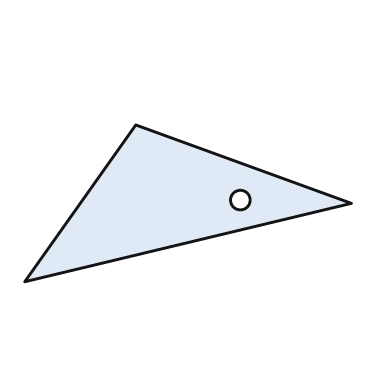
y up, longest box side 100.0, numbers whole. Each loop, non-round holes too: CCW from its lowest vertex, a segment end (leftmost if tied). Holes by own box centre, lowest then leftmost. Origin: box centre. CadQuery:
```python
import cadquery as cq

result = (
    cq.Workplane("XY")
    .moveTo(-50.0, -24.0)
    .lineTo(50.0, 0.0)
    .lineTo(-16.0, 24.0)
    .close()
    .moveTo(16.0, 1.0)
    .circle(3.0)
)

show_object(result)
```